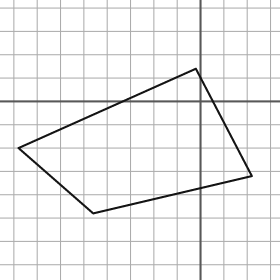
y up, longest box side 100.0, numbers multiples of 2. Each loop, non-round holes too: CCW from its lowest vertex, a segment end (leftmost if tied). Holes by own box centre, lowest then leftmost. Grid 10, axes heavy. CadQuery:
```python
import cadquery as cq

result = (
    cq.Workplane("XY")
    .moveTo(-46.0, -48.0)
    .lineTo(22.0, -32.0)
    .lineTo(-2.0, 14.0)
    .lineTo(-78.0, -20.0)
    .close()
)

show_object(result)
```